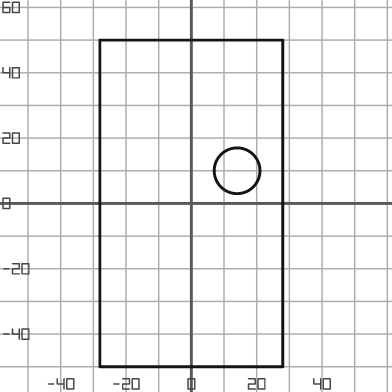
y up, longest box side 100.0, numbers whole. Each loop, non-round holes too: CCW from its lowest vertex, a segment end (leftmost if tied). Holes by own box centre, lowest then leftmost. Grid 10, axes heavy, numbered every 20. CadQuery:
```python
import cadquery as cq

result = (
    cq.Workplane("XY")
    .moveTo(-28.0, -50.0)
    .lineTo(28.0, -50.0)
    .lineTo(28.0, 50.0)
    .lineTo(-28.0, 50.0)
    .close()
    .moveTo(14.0, 10.0)
    .circle(7.0)
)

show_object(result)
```